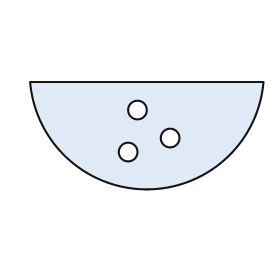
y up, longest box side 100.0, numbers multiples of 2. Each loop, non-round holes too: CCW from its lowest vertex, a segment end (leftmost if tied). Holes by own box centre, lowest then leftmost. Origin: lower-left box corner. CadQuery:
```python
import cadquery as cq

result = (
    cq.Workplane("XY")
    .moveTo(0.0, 46.0)
    .threePointArc((50.0, 0.0), (100.0, 46.0))
    .close()
    .moveTo(42.0, 16.0)
    .circle(4.0)
    .moveTo(60.0, 22.0)
    .circle(4.0)
    .moveTo(46.0, 34.0)
    .circle(4.0)
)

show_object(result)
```